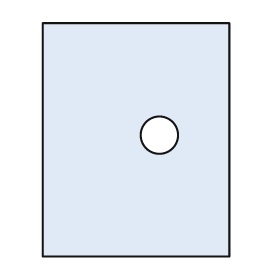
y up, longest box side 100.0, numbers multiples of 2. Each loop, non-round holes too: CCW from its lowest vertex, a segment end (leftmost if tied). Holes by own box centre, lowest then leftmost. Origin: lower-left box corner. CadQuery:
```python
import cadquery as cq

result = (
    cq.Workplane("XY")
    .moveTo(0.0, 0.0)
    .lineTo(80.0, 0.0)
    .lineTo(80.0, 100.0)
    .lineTo(0.0, 100.0)
    .close()
    .moveTo(50.0, 52.0)
    .circle(8.0)
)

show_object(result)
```